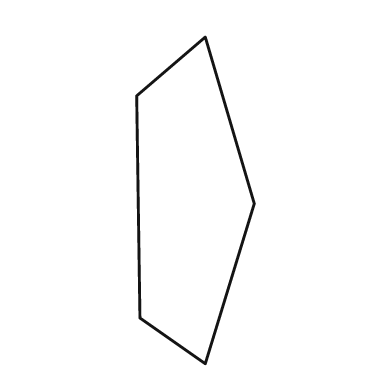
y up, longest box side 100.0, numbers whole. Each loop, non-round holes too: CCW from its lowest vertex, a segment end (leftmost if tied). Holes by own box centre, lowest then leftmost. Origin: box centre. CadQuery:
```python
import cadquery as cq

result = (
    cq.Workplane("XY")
    .moveTo(3.0, -50.0)
    .lineTo(18.0, -1.0)
    .lineTo(3.0, 50.0)
    .lineTo(-18.0, 32.0)
    .lineTo(-17.0, -36.0)
    .close()
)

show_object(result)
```